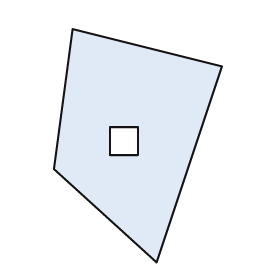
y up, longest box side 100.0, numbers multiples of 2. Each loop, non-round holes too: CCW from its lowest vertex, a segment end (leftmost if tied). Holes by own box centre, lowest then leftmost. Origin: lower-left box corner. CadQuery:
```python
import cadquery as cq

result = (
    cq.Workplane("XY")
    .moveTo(44.0, 0.0)
    .lineTo(72.0, 84.0)
    .lineTo(8.0, 100.0)
    .lineTo(0.0, 40.0)
    .close()
    .moveTo(24.0, 46.0)
    .lineTo(36.0, 46.0)
    .lineTo(36.0, 58.0)
    .lineTo(24.0, 58.0)
    .close()
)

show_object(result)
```